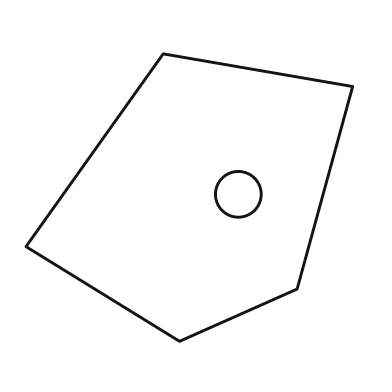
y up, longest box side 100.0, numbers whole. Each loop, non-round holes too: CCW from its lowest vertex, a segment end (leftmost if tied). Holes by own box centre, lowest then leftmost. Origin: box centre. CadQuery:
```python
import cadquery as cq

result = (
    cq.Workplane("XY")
    .moveTo(-3.0, -44.0)
    .lineTo(33.0, -28.0)
    .lineTo(50.0, 34.0)
    .lineTo(-8.0, 44.0)
    .lineTo(-50.0, -15.0)
    .close()
    .moveTo(15.0, 1.0)
    .circle(7.0)
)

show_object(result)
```